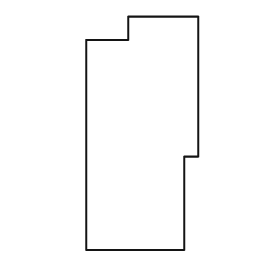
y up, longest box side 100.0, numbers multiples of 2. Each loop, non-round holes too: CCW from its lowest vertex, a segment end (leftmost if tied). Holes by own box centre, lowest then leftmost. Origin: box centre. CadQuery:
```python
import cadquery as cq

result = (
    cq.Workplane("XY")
    .moveTo(-24.0, -50.0)
    .lineTo(18.0, -50.0)
    .lineTo(18.0, -10.0)
    .lineTo(24.0, -10.0)
    .lineTo(24.0, 50.0)
    .lineTo(-6.0, 50.0)
    .lineTo(-6.0, 40.0)
    .lineTo(-24.0, 40.0)
    .close()
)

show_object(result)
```